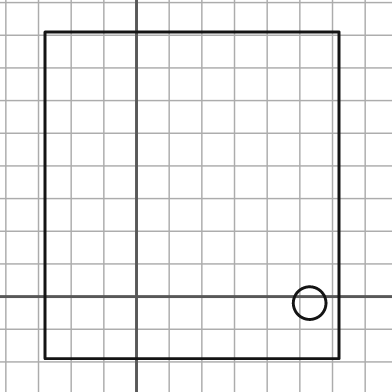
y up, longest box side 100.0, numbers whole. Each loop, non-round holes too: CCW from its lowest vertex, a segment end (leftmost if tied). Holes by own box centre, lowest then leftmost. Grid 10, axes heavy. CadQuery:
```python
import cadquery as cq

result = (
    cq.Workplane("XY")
    .moveTo(-28.0, -19.0)
    .lineTo(62.0, -19.0)
    .lineTo(62.0, 81.0)
    .lineTo(-28.0, 81.0)
    .close()
    .moveTo(53.0, -2.0)
    .circle(5.0)
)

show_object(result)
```